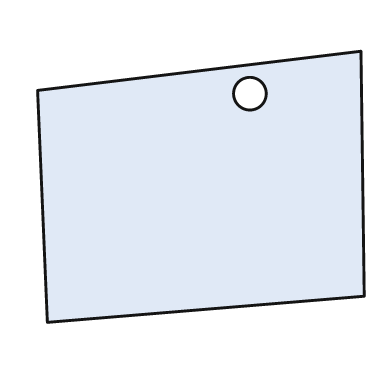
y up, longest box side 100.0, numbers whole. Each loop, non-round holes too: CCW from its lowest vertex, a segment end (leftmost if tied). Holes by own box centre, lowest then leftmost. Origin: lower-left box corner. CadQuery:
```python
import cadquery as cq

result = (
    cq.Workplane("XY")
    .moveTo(3.0, 0.0)
    .lineTo(100.0, 8.0)
    .lineTo(99.0, 83.0)
    .lineTo(0.0, 71.0)
    .close()
    .moveTo(65.0, 70.0)
    .circle(5.0)
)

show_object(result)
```